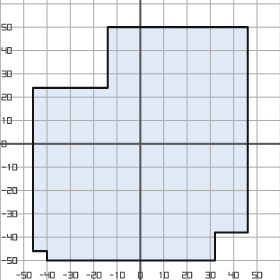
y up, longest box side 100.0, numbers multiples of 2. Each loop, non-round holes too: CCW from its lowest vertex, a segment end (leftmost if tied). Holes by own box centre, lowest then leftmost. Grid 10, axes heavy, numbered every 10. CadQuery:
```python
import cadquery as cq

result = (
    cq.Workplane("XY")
    .moveTo(-40.0, -50.0)
    .lineTo(32.0, -50.0)
    .lineTo(32.0, -38.0)
    .lineTo(46.0, -38.0)
    .lineTo(46.0, 50.0)
    .lineTo(-14.0, 50.0)
    .lineTo(-14.0, 24.0)
    .lineTo(-46.0, 24.0)
    .lineTo(-46.0, -46.0)
    .lineTo(-40.0, -46.0)
    .close()
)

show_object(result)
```